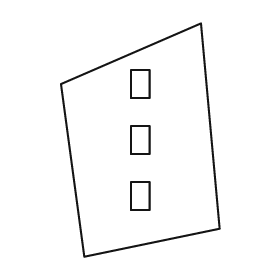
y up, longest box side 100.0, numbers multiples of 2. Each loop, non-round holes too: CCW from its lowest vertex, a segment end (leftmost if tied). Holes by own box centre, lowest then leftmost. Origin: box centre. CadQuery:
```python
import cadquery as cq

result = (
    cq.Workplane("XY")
    .moveTo(-24.0, -50.0)
    .lineTo(34.0, -38.0)
    .lineTo(26.0, 50.0)
    .lineTo(-34.0, 24.0)
    .close()
    .moveTo(-4.0, -30.0)
    .lineTo(4.0, -30.0)
    .lineTo(4.0, -18.0)
    .lineTo(-4.0, -18.0)
    .close()
    .moveTo(-4.0, -6.0)
    .lineTo(4.0, -6.0)
    .lineTo(4.0, 6.0)
    .lineTo(-4.0, 6.0)
    .close()
    .moveTo(-4.0, 18.0)
    .lineTo(4.0, 18.0)
    .lineTo(4.0, 30.0)
    .lineTo(-4.0, 30.0)
    .close()
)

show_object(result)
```